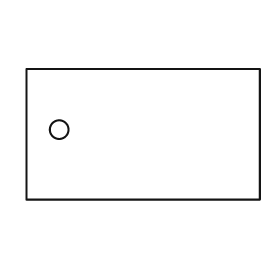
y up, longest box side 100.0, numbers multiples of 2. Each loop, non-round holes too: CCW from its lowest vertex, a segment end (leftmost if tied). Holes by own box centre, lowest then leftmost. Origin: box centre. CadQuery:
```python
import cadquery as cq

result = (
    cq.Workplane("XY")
    .moveTo(-50.0, -28.0)
    .lineTo(50.0, -28.0)
    .lineTo(50.0, 28.0)
    .lineTo(-50.0, 28.0)
    .close()
    .moveTo(-36.0, 2.0)
    .circle(4.0)
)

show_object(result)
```